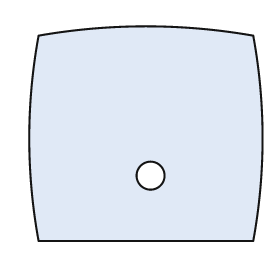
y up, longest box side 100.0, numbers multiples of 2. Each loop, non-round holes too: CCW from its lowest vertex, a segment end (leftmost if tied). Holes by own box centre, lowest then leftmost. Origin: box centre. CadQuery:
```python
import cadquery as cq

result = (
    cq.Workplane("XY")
    .moveTo(-46.0, -46.0)
    .lineTo(46.0, -46.0)
    .threePointArc((50.0, -2.0), (46.0, 42.0))
    .threePointArc((0.0, 46.0), (-46.0, 42.0))
    .threePointArc((-50.0, -2.0), (-46.0, -46.0))
    .close()
    .moveTo(2.0, -18.0)
    .circle(6.0)
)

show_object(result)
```